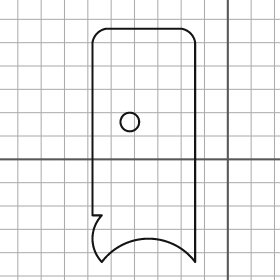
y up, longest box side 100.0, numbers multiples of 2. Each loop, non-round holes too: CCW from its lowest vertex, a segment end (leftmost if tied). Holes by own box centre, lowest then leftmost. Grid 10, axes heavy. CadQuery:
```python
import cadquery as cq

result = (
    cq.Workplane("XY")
    .moveTo(-54.0, -44.0)
    .threePointArc((-34.0, -34.0), (-14.0, -44.0))
    .lineTo(-14.0, 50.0)
    .threePointArc((-16.0, 54.0), (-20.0, 56.0))
    .lineTo(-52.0, 56.0)
    .threePointArc((-56.0, 54.0), (-58.0, 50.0))
    .lineTo(-58.0, -24.0)
    .lineTo(-54.0, -24.0)
    .threePointArc((-58.0, -34.0), (-54.0, -44.0))
    .close()
    .moveTo(-42.0, 16.0)
    .circle(4.0)
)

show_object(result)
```